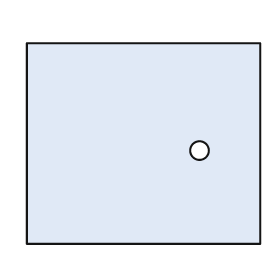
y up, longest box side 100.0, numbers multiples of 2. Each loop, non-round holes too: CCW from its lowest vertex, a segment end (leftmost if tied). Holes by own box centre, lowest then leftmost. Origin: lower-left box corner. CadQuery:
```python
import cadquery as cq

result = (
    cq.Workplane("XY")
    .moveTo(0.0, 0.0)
    .lineTo(100.0, 0.0)
    .lineTo(100.0, 86.0)
    .lineTo(0.0, 86.0)
    .close()
    .moveTo(74.0, 40.0)
    .circle(4.0)
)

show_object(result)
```